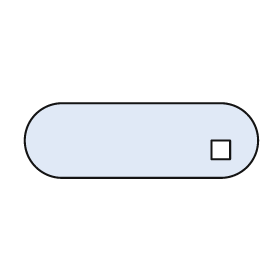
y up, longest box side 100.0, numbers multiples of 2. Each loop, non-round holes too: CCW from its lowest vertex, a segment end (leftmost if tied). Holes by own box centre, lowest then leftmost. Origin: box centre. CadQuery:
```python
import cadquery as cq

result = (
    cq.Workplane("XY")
    .moveTo(-34.0, -16.0)
    .lineTo(34.0, -16.0)
    .threePointArc((50.0, 0.0), (34.0, 16.0))
    .lineTo(-34.0, 16.0)
    .threePointArc((-50.0, 0.0), (-34.0, -16.0))
    .close()
    .moveTo(30.0, -8.0)
    .lineTo(38.0, -8.0)
    .lineTo(38.0, 0.0)
    .lineTo(30.0, 0.0)
    .close()
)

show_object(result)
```